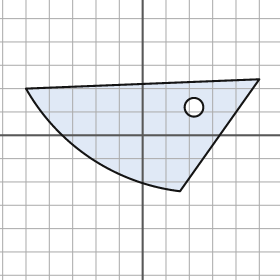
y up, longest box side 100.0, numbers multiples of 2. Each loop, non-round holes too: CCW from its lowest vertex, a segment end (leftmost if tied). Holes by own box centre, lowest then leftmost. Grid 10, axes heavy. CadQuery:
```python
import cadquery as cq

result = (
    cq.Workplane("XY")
    .moveTo(16.0, -24.0)
    .lineTo(50.0, 24.0)
    .lineTo(-50.0, 20.0)
    .threePointArc((-22.0, -10.0), (16.0, -24.0))
    .close()
    .moveTo(22.0, 12.0)
    .circle(4.0)
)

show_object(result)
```